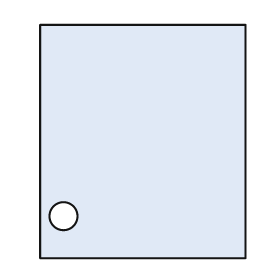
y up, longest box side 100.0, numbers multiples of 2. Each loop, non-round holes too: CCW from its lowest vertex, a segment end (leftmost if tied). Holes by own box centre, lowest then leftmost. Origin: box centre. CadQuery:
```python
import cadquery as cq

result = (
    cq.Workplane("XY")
    .moveTo(-44.0, -50.0)
    .lineTo(44.0, -50.0)
    .lineTo(44.0, 50.0)
    .lineTo(-44.0, 50.0)
    .close()
    .moveTo(-34.0, -32.0)
    .circle(6.0)
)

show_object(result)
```